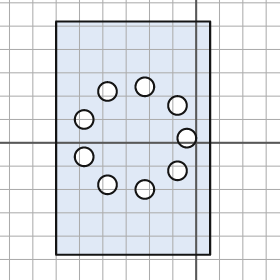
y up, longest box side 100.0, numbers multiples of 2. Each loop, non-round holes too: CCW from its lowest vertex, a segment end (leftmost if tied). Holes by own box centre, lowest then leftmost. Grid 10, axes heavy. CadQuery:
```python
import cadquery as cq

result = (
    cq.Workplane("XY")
    .moveTo(-60.0, -48.0)
    .lineTo(6.0, -48.0)
    .lineTo(6.0, 52.0)
    .lineTo(-60.0, 52.0)
    .close()
    .moveTo(-22.0, -20.0)
    .circle(4.0)
    .moveTo(-38.0, -18.0)
    .circle(4.0)
    .moveTo(-8.0, -12.0)
    .circle(4.0)
    .moveTo(-48.0, -6.0)
    .circle(4.0)
    .moveTo(-4.0, 2.0)
    .circle(4.0)
    .moveTo(-48.0, 10.0)
    .circle(4.0)
    .moveTo(-8.0, 16.0)
    .circle(4.0)
    .moveTo(-38.0, 22.0)
    .circle(4.0)
    .moveTo(-22.0, 24.0)
    .circle(4.0)
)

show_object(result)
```